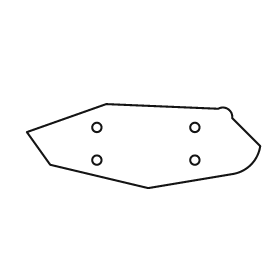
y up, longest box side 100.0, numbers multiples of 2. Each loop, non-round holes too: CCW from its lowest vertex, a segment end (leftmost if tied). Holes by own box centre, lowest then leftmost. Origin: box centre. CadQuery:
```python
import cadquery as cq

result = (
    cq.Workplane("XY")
    .moveTo(2.0, -18.0)
    .lineTo(38.0, -12.0)
    .threePointArc((46.0, -8.0), (50.0, 0.0))
    .lineTo(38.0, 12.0)
    .threePointArc((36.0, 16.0), (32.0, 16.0))
    .lineTo(-16.0, 18.0)
    .lineTo(-50.0, 6.0)
    .lineTo(-40.0, -8.0)
    .close()
    .moveTo(-20.0, -6.0)
    .circle(2.0)
    .moveTo(22.0, -6.0)
    .circle(2.0)
    .moveTo(-20.0, 8.0)
    .circle(2.0)
    .moveTo(22.0, 8.0)
    .circle(2.0)
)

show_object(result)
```